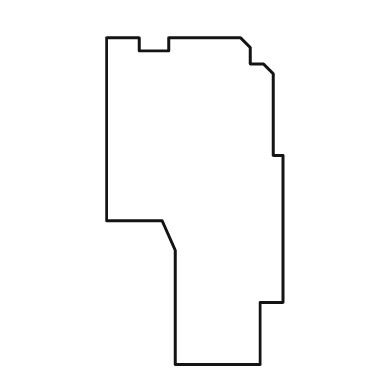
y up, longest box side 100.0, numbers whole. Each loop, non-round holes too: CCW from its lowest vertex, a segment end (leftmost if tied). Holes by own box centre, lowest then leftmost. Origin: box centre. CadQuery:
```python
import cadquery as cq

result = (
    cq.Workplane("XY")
    .moveTo(-6.0, -50.0)
    .lineTo(20.0, -50.0)
    .lineTo(20.0, -31.0)
    .lineTo(27.0, -31.0)
    .lineTo(27.0, 14.0)
    .lineTo(24.0, 14.0)
    .lineTo(24.0, 39.0)
    .lineTo(21.0, 42.0)
    .lineTo(17.0, 42.0)
    .lineTo(17.0, 47.0)
    .lineTo(14.0, 50.0)
    .lineTo(-8.0, 50.0)
    .lineTo(-8.0, 46.0)
    .lineTo(-17.0, 46.0)
    .lineTo(-17.0, 50.0)
    .lineTo(-27.0, 50.0)
    .lineTo(-27.0, -6.0)
    .lineTo(-10.0, -6.0)
    .lineTo(-6.0, -15.0)
    .close()
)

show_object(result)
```